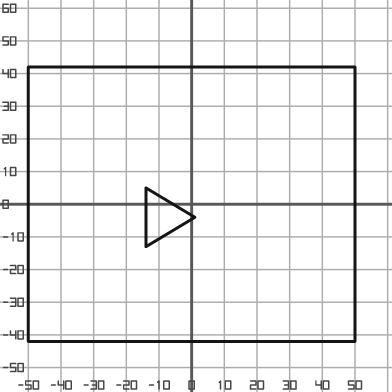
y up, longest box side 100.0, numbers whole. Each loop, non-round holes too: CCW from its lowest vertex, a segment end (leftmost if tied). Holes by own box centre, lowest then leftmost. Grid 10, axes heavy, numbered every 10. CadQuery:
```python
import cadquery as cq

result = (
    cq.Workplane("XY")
    .moveTo(-50.0, -42.0)
    .lineTo(50.0, -42.0)
    .lineTo(50.0, 42.0)
    .lineTo(-50.0, 42.0)
    .close()
    .moveTo(-14.0, -13.0)
    .lineTo(1.0, -4.0)
    .lineTo(-14.0, 5.0)
    .close()
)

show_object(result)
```